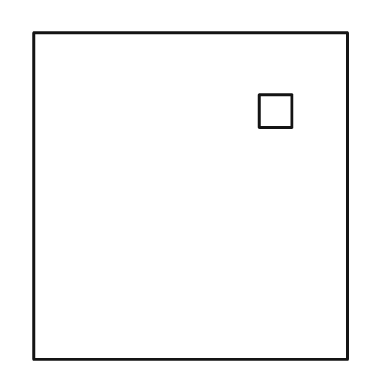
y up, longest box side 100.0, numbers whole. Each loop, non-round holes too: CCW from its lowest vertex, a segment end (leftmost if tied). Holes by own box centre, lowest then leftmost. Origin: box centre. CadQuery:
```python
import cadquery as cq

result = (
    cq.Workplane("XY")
    .moveTo(-48.0, -50.0)
    .lineTo(48.0, -50.0)
    .lineTo(48.0, 50.0)
    .lineTo(-48.0, 50.0)
    .close()
    .moveTo(21.0, 21.0)
    .lineTo(31.0, 21.0)
    .lineTo(31.0, 31.0)
    .lineTo(21.0, 31.0)
    .close()
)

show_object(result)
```